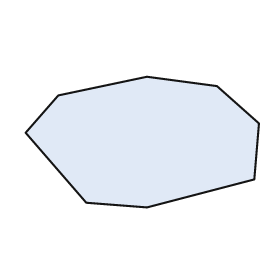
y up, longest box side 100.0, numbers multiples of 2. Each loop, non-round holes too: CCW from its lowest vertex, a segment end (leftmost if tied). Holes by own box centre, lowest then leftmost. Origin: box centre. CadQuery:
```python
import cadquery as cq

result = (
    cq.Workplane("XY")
    .moveTo(2.0, -28.0)
    .lineTo(48.0, -16.0)
    .lineTo(50.0, 8.0)
    .lineTo(32.0, 24.0)
    .lineTo(2.0, 28.0)
    .lineTo(-36.0, 20.0)
    .lineTo(-50.0, 4.0)
    .lineTo(-24.0, -26.0)
    .close()
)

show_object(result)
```